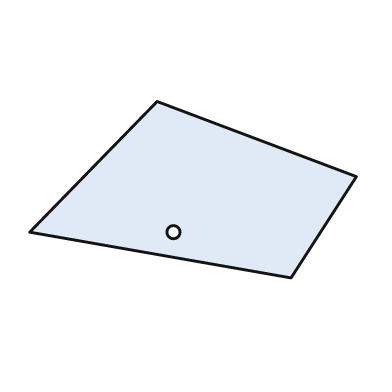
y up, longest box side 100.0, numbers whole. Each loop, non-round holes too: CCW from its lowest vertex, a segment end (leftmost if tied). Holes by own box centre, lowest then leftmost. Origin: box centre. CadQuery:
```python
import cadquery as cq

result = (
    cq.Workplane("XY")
    .moveTo(30.0, -27.0)
    .lineTo(50.0, 4.0)
    .lineTo(-11.0, 27.0)
    .lineTo(-50.0, -13.0)
    .close()
    .moveTo(-6.0, -13.0)
    .circle(2.0)
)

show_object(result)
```